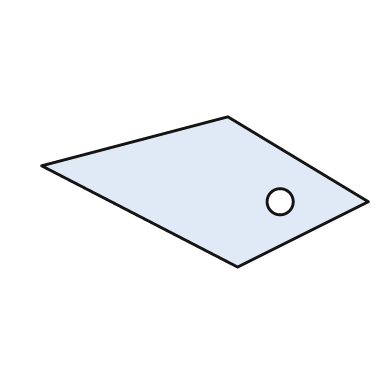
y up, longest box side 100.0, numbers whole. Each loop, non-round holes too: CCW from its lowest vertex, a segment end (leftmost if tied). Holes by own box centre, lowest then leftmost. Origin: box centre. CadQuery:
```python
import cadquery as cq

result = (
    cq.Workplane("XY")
    .moveTo(10.0, -23.0)
    .lineTo(50.0, -3.0)
    .lineTo(7.0, 23.0)
    .lineTo(-50.0, 8.0)
    .close()
    .moveTo(23.0, -3.0)
    .circle(4.0)
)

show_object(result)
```